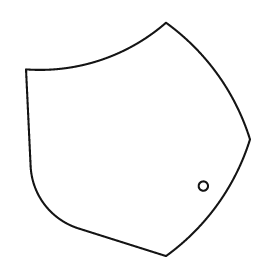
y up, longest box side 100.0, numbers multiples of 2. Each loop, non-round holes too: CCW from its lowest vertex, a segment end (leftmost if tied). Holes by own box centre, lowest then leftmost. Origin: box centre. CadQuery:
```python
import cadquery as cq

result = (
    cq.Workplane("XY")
    .moveTo(12.0, -50.0)
    .threePointArc((34.0, -28.0), (48.0, 0.0))
    .threePointArc((34.0, 28.0), (12.0, 50.0))
    .threePointArc((-16.0, 34.0), (-48.0, 30.0))
    .lineTo(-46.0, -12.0)
    .threePointArc((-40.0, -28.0), (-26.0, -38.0))
    .close()
    .moveTo(28.0, -20.0)
    .circle(2.0)
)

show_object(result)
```